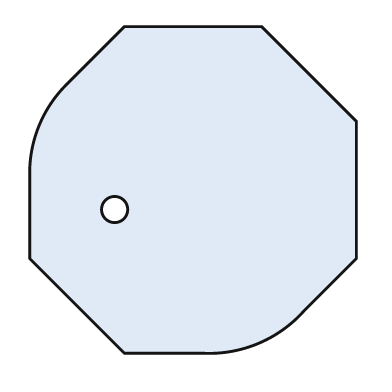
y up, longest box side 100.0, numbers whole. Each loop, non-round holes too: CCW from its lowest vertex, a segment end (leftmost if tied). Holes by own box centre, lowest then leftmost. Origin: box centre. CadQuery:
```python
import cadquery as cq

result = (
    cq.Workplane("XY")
    .moveTo(-21.0, -50.0)
    .lineTo(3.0, -50.0)
    .threePointArc((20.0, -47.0), (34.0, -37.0))
    .lineTo(50.0, -21.0)
    .lineTo(50.0, 21.0)
    .lineTo(21.0, 50.0)
    .lineTo(-21.0, 50.0)
    .lineTo(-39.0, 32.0)
    .threePointArc((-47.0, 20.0), (-50.0, 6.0))
    .lineTo(-50.0, -21.0)
    .close()
    .moveTo(-24.0, -6.0)
    .circle(4.0)
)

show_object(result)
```